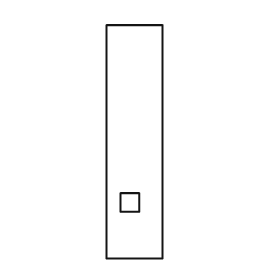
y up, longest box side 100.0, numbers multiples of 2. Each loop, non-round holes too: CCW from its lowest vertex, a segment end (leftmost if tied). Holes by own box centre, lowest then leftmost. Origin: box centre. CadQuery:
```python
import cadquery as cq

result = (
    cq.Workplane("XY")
    .moveTo(-12.0, -50.0)
    .lineTo(12.0, -50.0)
    .lineTo(12.0, 50.0)
    .lineTo(-12.0, 50.0)
    .close()
    .moveTo(-6.0, -30.0)
    .lineTo(2.0, -30.0)
    .lineTo(2.0, -22.0)
    .lineTo(-6.0, -22.0)
    .close()
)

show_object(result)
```